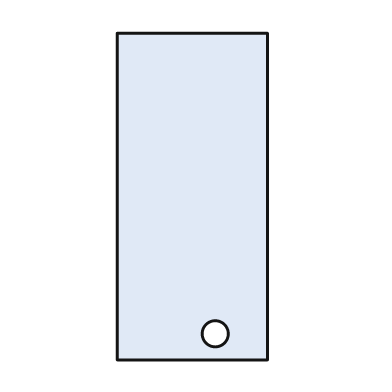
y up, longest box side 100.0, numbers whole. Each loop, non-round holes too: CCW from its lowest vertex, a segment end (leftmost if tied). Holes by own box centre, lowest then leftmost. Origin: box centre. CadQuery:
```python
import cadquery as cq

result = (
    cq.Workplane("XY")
    .moveTo(-23.0, -50.0)
    .lineTo(23.0, -50.0)
    .lineTo(23.0, 50.0)
    .lineTo(-23.0, 50.0)
    .close()
    .moveTo(7.0, -42.0)
    .circle(4.0)
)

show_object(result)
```